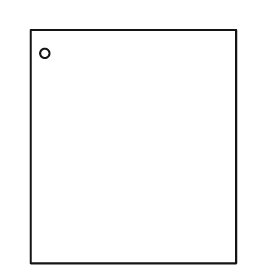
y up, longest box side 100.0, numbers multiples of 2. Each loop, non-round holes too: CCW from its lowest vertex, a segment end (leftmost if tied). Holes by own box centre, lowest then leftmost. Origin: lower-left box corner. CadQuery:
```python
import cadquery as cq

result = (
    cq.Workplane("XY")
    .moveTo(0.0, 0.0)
    .lineTo(88.0, 0.0)
    .lineTo(88.0, 100.0)
    .lineTo(0.0, 100.0)
    .close()
    .moveTo(6.0, 90.0)
    .circle(2.0)
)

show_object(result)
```